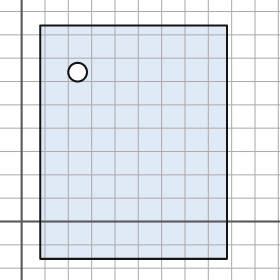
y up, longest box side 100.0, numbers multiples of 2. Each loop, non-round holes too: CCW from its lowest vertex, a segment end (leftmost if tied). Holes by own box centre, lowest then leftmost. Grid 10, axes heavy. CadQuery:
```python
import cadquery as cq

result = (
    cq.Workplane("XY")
    .moveTo(8.0, -16.0)
    .lineTo(88.0, -16.0)
    .lineTo(88.0, 84.0)
    .lineTo(8.0, 84.0)
    .close()
    .moveTo(24.0, 64.0)
    .circle(4.0)
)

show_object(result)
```